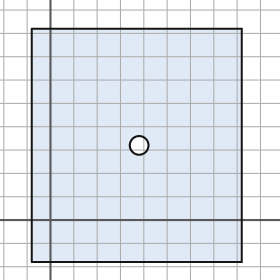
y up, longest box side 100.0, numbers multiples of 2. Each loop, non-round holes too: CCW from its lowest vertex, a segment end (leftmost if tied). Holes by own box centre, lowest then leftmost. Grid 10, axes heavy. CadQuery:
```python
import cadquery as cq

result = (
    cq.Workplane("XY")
    .moveTo(-8.0, -18.0)
    .lineTo(82.0, -18.0)
    .lineTo(82.0, 82.0)
    .lineTo(-8.0, 82.0)
    .close()
    .moveTo(38.0, 32.0)
    .circle(4.0)
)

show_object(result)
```